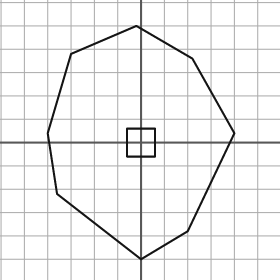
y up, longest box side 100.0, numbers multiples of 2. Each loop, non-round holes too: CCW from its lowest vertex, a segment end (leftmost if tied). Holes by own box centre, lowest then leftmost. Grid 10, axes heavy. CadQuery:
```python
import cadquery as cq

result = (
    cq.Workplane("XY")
    .moveTo(0.0, -50.0)
    .lineTo(20.0, -38.0)
    .lineTo(40.0, 4.0)
    .lineTo(22.0, 36.0)
    .lineTo(-2.0, 50.0)
    .lineTo(-30.0, 38.0)
    .lineTo(-40.0, 4.0)
    .lineTo(-36.0, -22.0)
    .close()
    .moveTo(-6.0, -6.0)
    .lineTo(6.0, -6.0)
    .lineTo(6.0, 6.0)
    .lineTo(-6.0, 6.0)
    .close()
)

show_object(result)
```